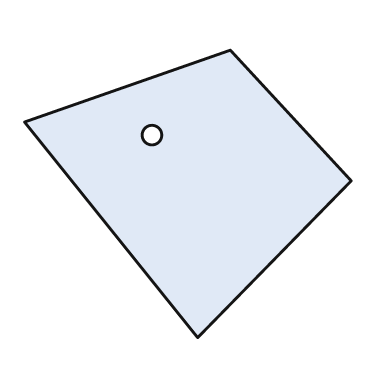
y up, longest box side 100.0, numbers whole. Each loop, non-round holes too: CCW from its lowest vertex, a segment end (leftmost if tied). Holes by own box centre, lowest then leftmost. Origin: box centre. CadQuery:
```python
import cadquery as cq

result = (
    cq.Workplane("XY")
    .moveTo(3.0, -44.0)
    .lineTo(50.0, 4.0)
    .lineTo(13.0, 44.0)
    .lineTo(-50.0, 22.0)
    .close()
    .moveTo(-11.0, 18.0)
    .circle(3.0)
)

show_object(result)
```